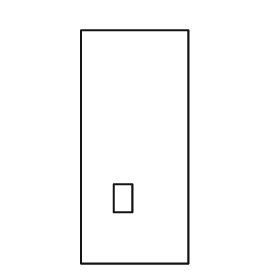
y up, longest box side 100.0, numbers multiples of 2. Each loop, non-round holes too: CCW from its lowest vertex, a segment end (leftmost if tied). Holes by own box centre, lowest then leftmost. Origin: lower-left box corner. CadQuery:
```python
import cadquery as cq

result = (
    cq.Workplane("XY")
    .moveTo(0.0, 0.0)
    .lineTo(46.0, 0.0)
    .lineTo(46.0, 100.0)
    .lineTo(0.0, 100.0)
    .close()
    .moveTo(14.0, 22.0)
    .lineTo(22.0, 22.0)
    .lineTo(22.0, 34.0)
    .lineTo(14.0, 34.0)
    .close()
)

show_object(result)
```